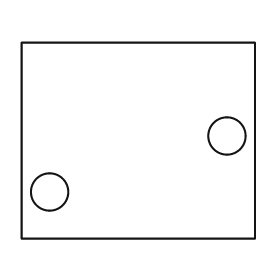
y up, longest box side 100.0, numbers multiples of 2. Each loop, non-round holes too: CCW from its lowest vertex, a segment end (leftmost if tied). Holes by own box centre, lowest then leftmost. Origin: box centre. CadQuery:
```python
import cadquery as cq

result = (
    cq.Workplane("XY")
    .moveTo(-50.0, -42.0)
    .lineTo(50.0, -42.0)
    .lineTo(50.0, 42.0)
    .lineTo(-50.0, 42.0)
    .close()
    .moveTo(-38.0, -22.0)
    .circle(8.0)
    .moveTo(38.0, 2.0)
    .circle(8.0)
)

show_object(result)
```